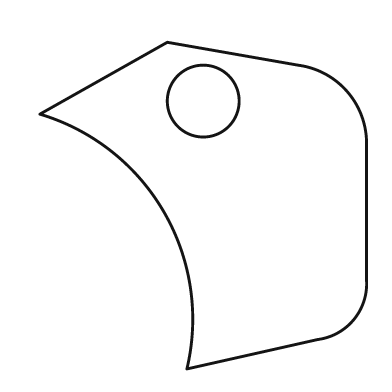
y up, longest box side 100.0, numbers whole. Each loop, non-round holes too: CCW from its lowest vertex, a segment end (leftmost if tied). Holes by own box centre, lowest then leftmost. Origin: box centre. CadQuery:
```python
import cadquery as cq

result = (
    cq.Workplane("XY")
    .moveTo(-5.0, -50.0)
    .lineTo(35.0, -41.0)
    .threePointArc((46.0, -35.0), (50.0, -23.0))
    .lineTo(50.0, 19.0)
    .threePointArc((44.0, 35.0), (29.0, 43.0))
    .lineTo(-11.0, 50.0)
    .lineTo(-50.0, 28.0)
    .threePointArc((-12.0, -2.0), (-5.0, -50.0))
    .close()
    .moveTo(0.0, 32.0)
    .circle(11.0)
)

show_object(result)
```